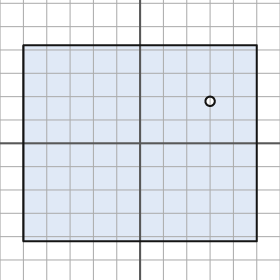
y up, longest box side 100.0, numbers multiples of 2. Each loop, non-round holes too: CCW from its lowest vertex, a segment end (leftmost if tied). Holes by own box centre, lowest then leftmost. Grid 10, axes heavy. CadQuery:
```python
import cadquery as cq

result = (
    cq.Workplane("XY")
    .moveTo(-50.0, -42.0)
    .lineTo(50.0, -42.0)
    .lineTo(50.0, 42.0)
    .lineTo(-50.0, 42.0)
    .close()
    .moveTo(30.0, 18.0)
    .circle(2.0)
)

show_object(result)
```